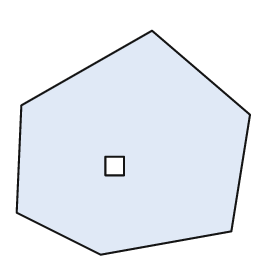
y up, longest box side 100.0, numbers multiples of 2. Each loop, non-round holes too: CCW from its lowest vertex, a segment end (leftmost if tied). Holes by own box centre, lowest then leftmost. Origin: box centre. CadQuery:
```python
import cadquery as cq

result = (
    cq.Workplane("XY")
    .moveTo(-14.0, -48.0)
    .lineTo(42.0, -38.0)
    .lineTo(50.0, 12.0)
    .lineTo(8.0, 48.0)
    .lineTo(-48.0, 16.0)
    .lineTo(-50.0, -30.0)
    .close()
    .moveTo(-12.0, -14.0)
    .lineTo(-4.0, -14.0)
    .lineTo(-4.0, -6.0)
    .lineTo(-12.0, -6.0)
    .close()
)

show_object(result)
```